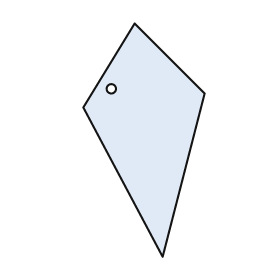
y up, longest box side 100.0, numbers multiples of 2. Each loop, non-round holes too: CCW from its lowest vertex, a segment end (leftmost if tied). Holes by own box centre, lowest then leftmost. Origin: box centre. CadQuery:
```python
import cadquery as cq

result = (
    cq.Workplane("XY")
    .moveTo(8.0, -50.0)
    .lineTo(26.0, 20.0)
    .lineTo(-4.0, 50.0)
    .lineTo(-26.0, 14.0)
    .close()
    .moveTo(-14.0, 22.0)
    .circle(2.0)
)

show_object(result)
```